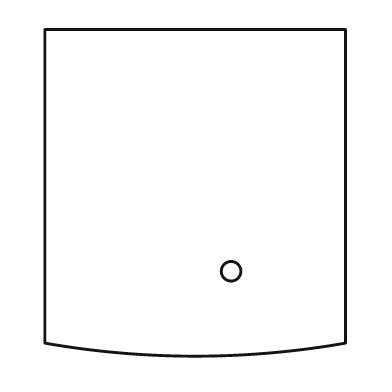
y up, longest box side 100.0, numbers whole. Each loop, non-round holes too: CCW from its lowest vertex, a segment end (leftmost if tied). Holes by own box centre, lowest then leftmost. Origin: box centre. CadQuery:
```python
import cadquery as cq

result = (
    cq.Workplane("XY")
    .moveTo(-46.0, -46.0)
    .threePointArc((0.0, -50.0), (46.0, -46.0))
    .lineTo(46.0, 50.0)
    .lineTo(-46.0, 50.0)
    .close()
    .moveTo(11.0, -24.0)
    .circle(3.0)
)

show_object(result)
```